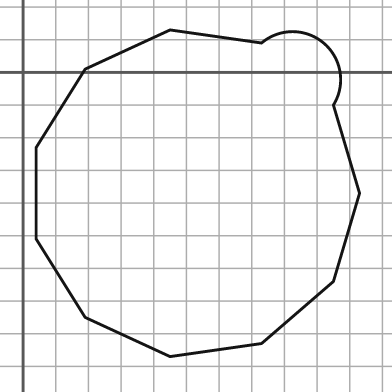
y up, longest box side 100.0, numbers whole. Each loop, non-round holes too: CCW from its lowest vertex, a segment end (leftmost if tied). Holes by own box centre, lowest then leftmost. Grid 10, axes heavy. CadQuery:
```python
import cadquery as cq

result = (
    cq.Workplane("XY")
    .moveTo(45.0, -87.0)
    .lineTo(73.0, -83.0)
    .lineTo(95.0, -64.0)
    .lineTo(103.0, -37.0)
    .lineTo(95.0, -10.0)
    .threePointArc((92.0, 9.0), (73.0, 9.0))
    .lineTo(45.0, 13.0)
    .lineTo(19.0, 1.0)
    .lineTo(4.0, -23.0)
    .lineTo(4.0, -51.0)
    .lineTo(19.0, -75.0)
    .close()
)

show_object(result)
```